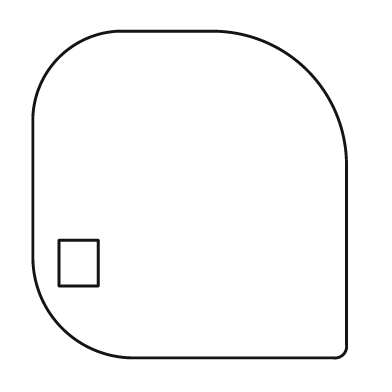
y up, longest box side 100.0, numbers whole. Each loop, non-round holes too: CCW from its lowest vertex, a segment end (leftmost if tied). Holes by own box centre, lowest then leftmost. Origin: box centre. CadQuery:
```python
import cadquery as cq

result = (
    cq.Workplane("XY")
    .moveTo(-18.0, -50.0)
    .lineTo(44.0, -50.0)
    .threePointArc((47.0, -49.0), (48.0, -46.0))
    .lineTo(48.0, 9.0)
    .threePointArc((36.0, 38.0), (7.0, 50.0))
    .lineTo(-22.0, 50.0)
    .threePointArc((-40.0, 42.0), (-48.0, 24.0))
    .lineTo(-48.0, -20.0)
    .threePointArc((-39.0, -41.0), (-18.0, -50.0))
    .close()
    .moveTo(-40.0, -28.0)
    .lineTo(-28.0, -28.0)
    .lineTo(-28.0, -14.0)
    .lineTo(-40.0, -14.0)
    .close()
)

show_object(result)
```